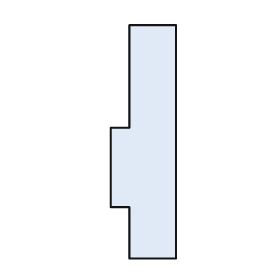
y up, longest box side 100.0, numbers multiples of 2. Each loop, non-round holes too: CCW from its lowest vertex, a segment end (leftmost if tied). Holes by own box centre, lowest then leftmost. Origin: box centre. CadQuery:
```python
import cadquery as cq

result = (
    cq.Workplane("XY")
    .moveTo(-6.0, -50.0)
    .lineTo(14.0, -50.0)
    .lineTo(14.0, 50.0)
    .lineTo(-6.0, 50.0)
    .lineTo(-6.0, 6.0)
    .lineTo(-14.0, 6.0)
    .lineTo(-14.0, -28.0)
    .lineTo(-6.0, -28.0)
    .close()
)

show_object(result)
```